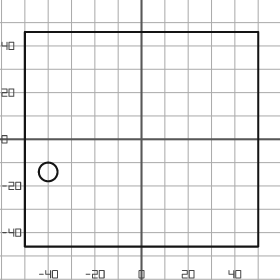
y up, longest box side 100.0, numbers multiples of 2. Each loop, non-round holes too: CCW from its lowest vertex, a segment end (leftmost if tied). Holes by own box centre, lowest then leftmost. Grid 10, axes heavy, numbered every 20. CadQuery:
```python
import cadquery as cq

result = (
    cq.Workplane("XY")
    .moveTo(-50.0, -46.0)
    .lineTo(50.0, -46.0)
    .lineTo(50.0, 46.0)
    .lineTo(-50.0, 46.0)
    .close()
    .moveTo(-40.0, -14.0)
    .circle(4.0)
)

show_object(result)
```